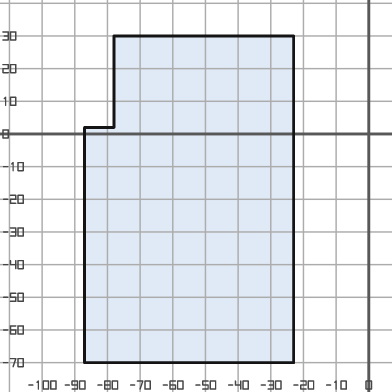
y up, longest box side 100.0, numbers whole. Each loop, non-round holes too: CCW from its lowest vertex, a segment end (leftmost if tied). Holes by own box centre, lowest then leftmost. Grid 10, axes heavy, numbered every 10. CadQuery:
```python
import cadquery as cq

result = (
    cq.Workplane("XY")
    .moveTo(-87.0, -70.0)
    .lineTo(-23.0, -70.0)
    .lineTo(-23.0, 30.0)
    .lineTo(-78.0, 30.0)
    .lineTo(-78.0, 2.0)
    .lineTo(-87.0, 2.0)
    .close()
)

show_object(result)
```